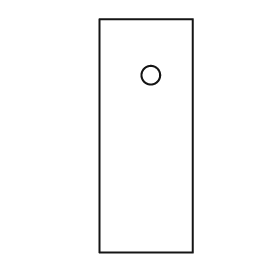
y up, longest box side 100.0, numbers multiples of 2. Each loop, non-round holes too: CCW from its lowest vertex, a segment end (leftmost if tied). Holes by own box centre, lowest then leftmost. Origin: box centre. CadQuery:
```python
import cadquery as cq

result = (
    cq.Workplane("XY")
    .moveTo(-20.0, -50.0)
    .lineTo(20.0, -50.0)
    .lineTo(20.0, 50.0)
    .lineTo(-20.0, 50.0)
    .close()
    .moveTo(2.0, 26.0)
    .circle(4.0)
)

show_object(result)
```